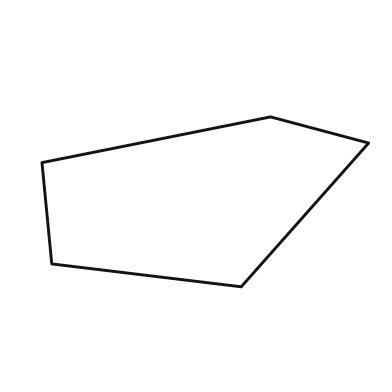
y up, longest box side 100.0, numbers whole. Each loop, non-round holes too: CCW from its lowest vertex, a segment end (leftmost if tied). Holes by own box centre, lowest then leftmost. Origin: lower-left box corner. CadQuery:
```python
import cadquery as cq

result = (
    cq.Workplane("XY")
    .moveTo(61.0, 0.0)
    .lineTo(100.0, 44.0)
    .lineTo(70.0, 52.0)
    .lineTo(0.0, 38.0)
    .lineTo(3.0, 7.0)
    .close()
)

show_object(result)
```